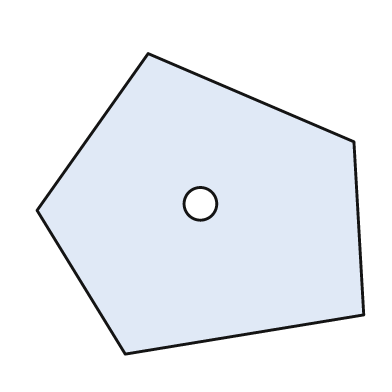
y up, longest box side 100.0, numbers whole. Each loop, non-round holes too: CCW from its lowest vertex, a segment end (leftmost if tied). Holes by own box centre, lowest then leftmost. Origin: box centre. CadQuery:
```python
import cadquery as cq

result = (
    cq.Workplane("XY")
    .moveTo(-23.0, -46.0)
    .lineTo(50.0, -34.0)
    .lineTo(47.0, 19.0)
    .lineTo(-16.0, 46.0)
    .lineTo(-50.0, -2.0)
    .close()
    .moveTo(0.0, 0.0)
    .circle(5.0)
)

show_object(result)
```